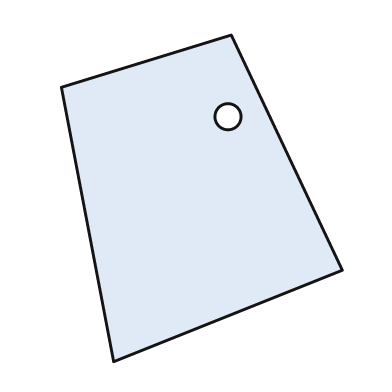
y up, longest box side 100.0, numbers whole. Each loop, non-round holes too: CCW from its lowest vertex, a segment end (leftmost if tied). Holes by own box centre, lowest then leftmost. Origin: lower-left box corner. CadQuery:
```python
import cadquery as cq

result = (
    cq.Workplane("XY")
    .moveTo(16.0, 0.0)
    .lineTo(86.0, 28.0)
    .lineTo(52.0, 100.0)
    .lineTo(0.0, 84.0)
    .close()
    .moveTo(51.0, 75.0)
    .circle(4.0)
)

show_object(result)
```